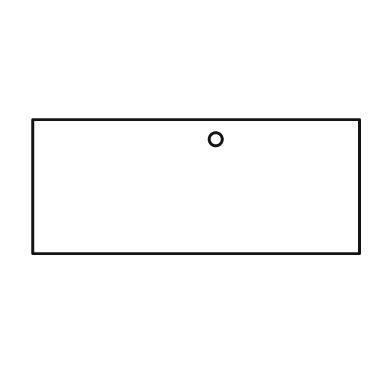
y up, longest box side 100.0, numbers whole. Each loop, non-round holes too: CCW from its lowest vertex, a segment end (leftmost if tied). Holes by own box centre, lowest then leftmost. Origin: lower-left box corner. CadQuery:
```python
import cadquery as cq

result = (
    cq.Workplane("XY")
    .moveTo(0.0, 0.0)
    .lineTo(100.0, 0.0)
    .lineTo(100.0, 41.0)
    .lineTo(0.0, 41.0)
    .close()
    .moveTo(56.0, 35.0)
    .circle(2.0)
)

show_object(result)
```